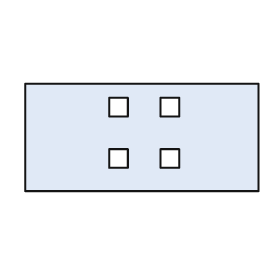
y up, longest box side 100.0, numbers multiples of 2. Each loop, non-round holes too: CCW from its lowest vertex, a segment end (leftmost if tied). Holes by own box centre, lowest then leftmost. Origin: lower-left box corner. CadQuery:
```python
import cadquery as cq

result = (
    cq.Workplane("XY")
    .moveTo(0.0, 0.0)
    .lineTo(100.0, 0.0)
    .lineTo(100.0, 46.0)
    .lineTo(0.0, 46.0)
    .close()
    .moveTo(36.0, 10.0)
    .lineTo(44.0, 10.0)
    .lineTo(44.0, 18.0)
    .lineTo(36.0, 18.0)
    .close()
    .moveTo(58.0, 10.0)
    .lineTo(66.0, 10.0)
    .lineTo(66.0, 18.0)
    .lineTo(58.0, 18.0)
    .close()
    .moveTo(36.0, 32.0)
    .lineTo(44.0, 32.0)
    .lineTo(44.0, 40.0)
    .lineTo(36.0, 40.0)
    .close()
    .moveTo(58.0, 32.0)
    .lineTo(66.0, 32.0)
    .lineTo(66.0, 40.0)
    .lineTo(58.0, 40.0)
    .close()
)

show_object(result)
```